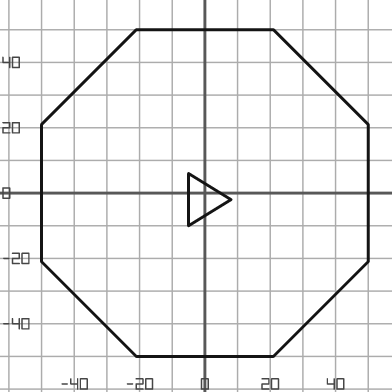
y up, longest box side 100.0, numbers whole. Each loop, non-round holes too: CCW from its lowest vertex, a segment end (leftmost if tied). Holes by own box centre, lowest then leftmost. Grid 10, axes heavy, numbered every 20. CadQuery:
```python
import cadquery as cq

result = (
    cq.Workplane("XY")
    .moveTo(-21.0, -50.0)
    .lineTo(21.0, -50.0)
    .lineTo(50.0, -21.0)
    .lineTo(50.0, 21.0)
    .lineTo(21.0, 50.0)
    .lineTo(-21.0, 50.0)
    .lineTo(-50.0, 21.0)
    .lineTo(-50.0, -21.0)
    .close()
    .moveTo(-5.0, -10.0)
    .lineTo(8.0, -2.0)
    .lineTo(-5.0, 6.0)
    .close()
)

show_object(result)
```